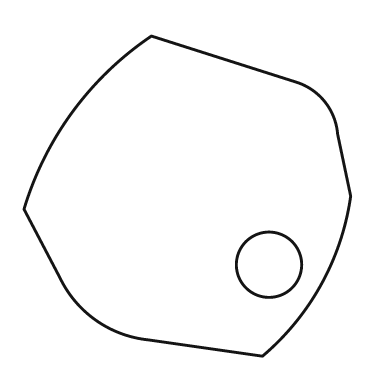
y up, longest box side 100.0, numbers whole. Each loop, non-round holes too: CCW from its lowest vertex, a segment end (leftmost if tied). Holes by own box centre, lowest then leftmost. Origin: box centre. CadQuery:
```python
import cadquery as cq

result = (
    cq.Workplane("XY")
    .moveTo(23.0, -49.0)
    .threePointArc((41.0, -27.0), (50.0, 0.0))
    .lineTo(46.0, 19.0)
    .threePointArc((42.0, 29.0), (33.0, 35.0))
    .lineTo(-11.0, 49.0)
    .threePointArc((-35.0, 26.0), (-50.0, -4.0))
    .lineTo(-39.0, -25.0)
    .threePointArc((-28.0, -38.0), (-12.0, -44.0))
    .close()
    .moveTo(25.0, -21.0)
    .circle(10.0)
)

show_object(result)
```